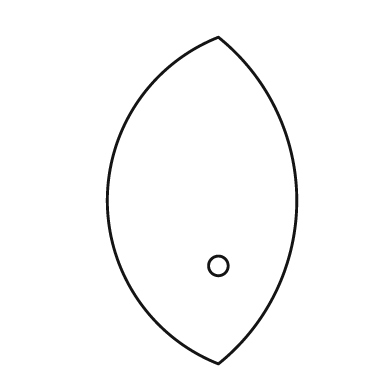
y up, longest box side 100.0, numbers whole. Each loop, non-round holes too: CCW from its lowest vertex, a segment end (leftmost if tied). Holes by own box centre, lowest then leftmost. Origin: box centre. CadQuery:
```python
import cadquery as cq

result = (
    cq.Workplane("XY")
    .moveTo(5.0, -50.0)
    .threePointArc((29.0, 0.0), (5.0, 50.0))
    .threePointArc((-29.0, 0.0), (5.0, -50.0))
    .close()
    .moveTo(5.0, -20.0)
    .circle(3.0)
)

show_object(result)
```